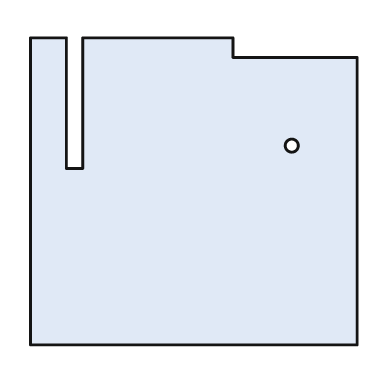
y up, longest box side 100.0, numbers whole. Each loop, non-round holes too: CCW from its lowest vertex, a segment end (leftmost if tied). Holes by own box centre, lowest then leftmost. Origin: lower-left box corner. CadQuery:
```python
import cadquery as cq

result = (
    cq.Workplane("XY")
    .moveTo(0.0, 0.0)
    .lineTo(100.0, 0.0)
    .lineTo(100.0, 88.0)
    .lineTo(62.0, 88.0)
    .lineTo(62.0, 94.0)
    .lineTo(16.0, 94.0)
    .lineTo(16.0, 54.0)
    .lineTo(11.0, 54.0)
    .lineTo(11.0, 94.0)
    .lineTo(0.0, 94.0)
    .close()
    .moveTo(80.0, 61.0)
    .circle(2.0)
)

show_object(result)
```